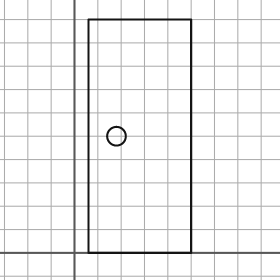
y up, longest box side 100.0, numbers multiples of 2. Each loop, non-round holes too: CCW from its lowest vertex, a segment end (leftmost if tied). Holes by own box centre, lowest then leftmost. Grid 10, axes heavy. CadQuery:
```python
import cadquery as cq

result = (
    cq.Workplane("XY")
    .moveTo(6.0, 0.0)
    .lineTo(50.0, 0.0)
    .lineTo(50.0, 100.0)
    .lineTo(6.0, 100.0)
    .close()
    .moveTo(18.0, 50.0)
    .circle(4.0)
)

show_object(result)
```